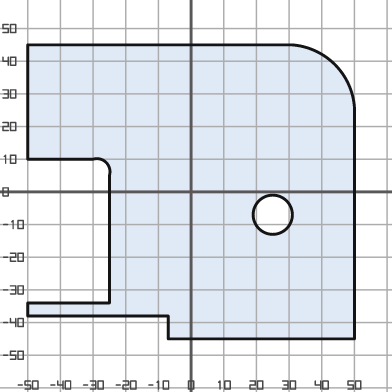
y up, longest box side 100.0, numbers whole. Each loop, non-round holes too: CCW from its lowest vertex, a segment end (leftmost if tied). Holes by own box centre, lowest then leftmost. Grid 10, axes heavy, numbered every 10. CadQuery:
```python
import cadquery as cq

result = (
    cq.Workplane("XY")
    .moveTo(-7.0, -45.0)
    .lineTo(50.0, -45.0)
    .lineTo(50.0, 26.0)
    .threePointArc((44.0, 39.0), (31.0, 45.0))
    .lineTo(-50.0, 45.0)
    .lineTo(-50.0, 10.0)
    .lineTo(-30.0, 10.0)
    .threePointArc((-26.0, 9.0), (-25.0, 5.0))
    .lineTo(-25.0, -34.0)
    .lineTo(-50.0, -34.0)
    .lineTo(-50.0, -38.0)
    .lineTo(-7.0, -38.0)
    .close()
    .moveTo(25.0, -7.0)
    .circle(6.0)
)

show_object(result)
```